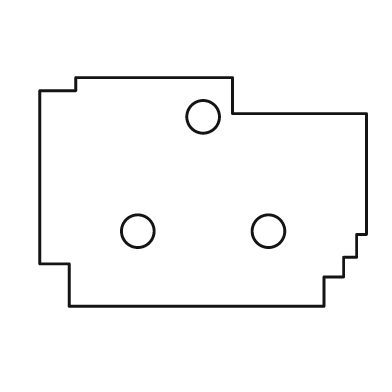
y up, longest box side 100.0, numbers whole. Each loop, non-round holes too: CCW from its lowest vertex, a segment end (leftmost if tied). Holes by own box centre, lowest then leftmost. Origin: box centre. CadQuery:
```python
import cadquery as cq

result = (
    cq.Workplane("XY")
    .moveTo(-41.0, -35.0)
    .lineTo(37.0, -35.0)
    .lineTo(37.0, -26.0)
    .lineTo(43.0, -26.0)
    .lineTo(43.0, -20.0)
    .lineTo(47.0, -20.0)
    .lineTo(47.0, -13.0)
    .lineTo(50.0, -13.0)
    .lineTo(50.0, 24.0)
    .lineTo(9.0, 24.0)
    .lineTo(9.0, 35.0)
    .lineTo(-39.0, 35.0)
    .lineTo(-39.0, 31.0)
    .lineTo(-50.0, 31.0)
    .lineTo(-50.0, -22.0)
    .lineTo(-41.0, -22.0)
    .close()
    .moveTo(-20.0, -12.0)
    .circle(5.0)
    .moveTo(20.0, -12.0)
    .circle(5.0)
    .moveTo(0.0, 23.0)
    .circle(5.0)
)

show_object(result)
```